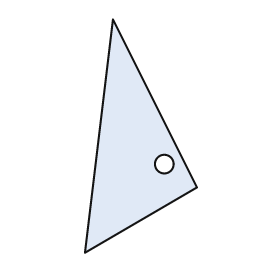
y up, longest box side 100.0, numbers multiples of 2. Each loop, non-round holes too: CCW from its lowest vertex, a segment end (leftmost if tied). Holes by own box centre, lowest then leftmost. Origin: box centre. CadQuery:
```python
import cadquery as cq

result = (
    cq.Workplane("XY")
    .moveTo(-24.0, -50.0)
    .lineTo(24.0, -22.0)
    .lineTo(-12.0, 50.0)
    .close()
    .moveTo(10.0, -12.0)
    .circle(4.0)
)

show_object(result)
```